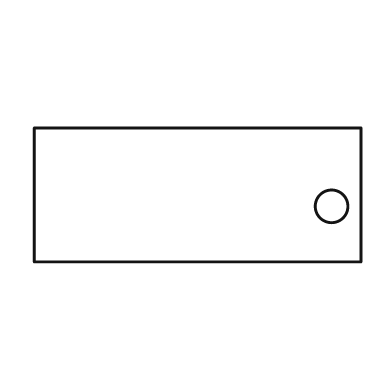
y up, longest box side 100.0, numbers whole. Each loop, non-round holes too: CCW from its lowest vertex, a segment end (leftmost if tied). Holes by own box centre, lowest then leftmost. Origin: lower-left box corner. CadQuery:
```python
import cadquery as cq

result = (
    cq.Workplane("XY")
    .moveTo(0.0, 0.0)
    .lineTo(100.0, 0.0)
    .lineTo(100.0, 41.0)
    .lineTo(0.0, 41.0)
    .close()
    .moveTo(91.0, 17.0)
    .circle(5.0)
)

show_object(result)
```